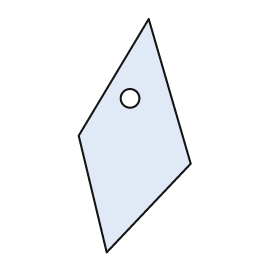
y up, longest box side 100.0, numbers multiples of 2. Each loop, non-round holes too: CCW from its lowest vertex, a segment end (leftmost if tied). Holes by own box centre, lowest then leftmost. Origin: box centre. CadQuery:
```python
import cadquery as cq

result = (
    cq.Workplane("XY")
    .moveTo(-12.0, -50.0)
    .lineTo(24.0, -12.0)
    .lineTo(6.0, 50.0)
    .lineTo(-24.0, 0.0)
    .close()
    .moveTo(-2.0, 16.0)
    .circle(4.0)
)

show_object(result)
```